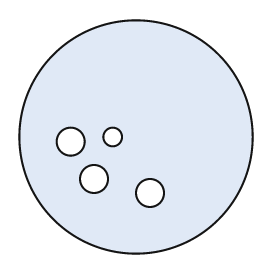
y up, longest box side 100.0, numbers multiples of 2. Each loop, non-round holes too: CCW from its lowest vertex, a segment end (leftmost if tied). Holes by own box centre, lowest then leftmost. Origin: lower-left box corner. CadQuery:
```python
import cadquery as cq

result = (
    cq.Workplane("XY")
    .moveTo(50.0, 50.0)
    .circle(50.0)
    .moveTo(56.0, 26.0)
    .circle(6.0)
    .moveTo(32.0, 32.0)
    .circle(6.0)
    .moveTo(22.0, 48.0)
    .circle(6.0)
    .moveTo(40.0, 50.0)
    .circle(4.0)
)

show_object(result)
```